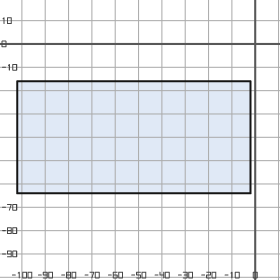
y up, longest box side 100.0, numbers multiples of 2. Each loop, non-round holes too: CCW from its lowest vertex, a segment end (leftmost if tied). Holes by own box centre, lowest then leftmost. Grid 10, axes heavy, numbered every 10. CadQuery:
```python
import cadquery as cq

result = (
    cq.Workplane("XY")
    .moveTo(-102.0, -64.0)
    .lineTo(-2.0, -64.0)
    .lineTo(-2.0, -16.0)
    .lineTo(-102.0, -16.0)
    .close()
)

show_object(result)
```